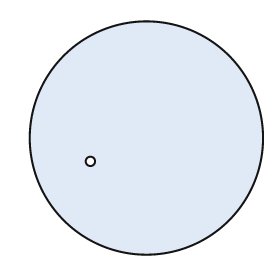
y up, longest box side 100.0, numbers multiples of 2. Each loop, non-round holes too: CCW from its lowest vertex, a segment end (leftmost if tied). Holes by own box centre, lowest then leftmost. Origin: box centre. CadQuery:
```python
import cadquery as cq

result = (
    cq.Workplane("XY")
    .moveTo(0.0, 0.0)
    .circle(50.0)
    .moveTo(-24.0, -10.0)
    .circle(2.0)
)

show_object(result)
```